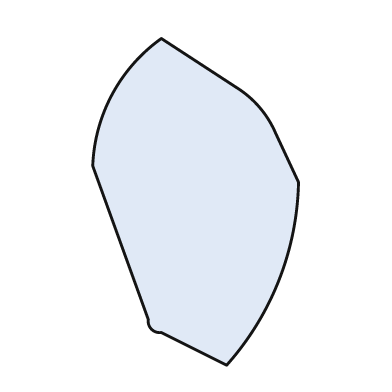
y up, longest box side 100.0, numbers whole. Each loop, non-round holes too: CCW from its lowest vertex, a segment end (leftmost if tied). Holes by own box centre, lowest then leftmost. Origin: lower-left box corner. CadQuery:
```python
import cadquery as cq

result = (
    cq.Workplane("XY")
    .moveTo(41.0, 0.0)
    .threePointArc((57.0, 26.0), (63.0, 56.0))
    .lineTo(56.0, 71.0)
    .threePointArc((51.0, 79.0), (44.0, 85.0))
    .lineTo(21.0, 100.0)
    .threePointArc((6.0, 83.0), (0.0, 61.0))
    .lineTo(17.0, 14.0)
    .threePointArc((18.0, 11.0), (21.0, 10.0))
    .close()
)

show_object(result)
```